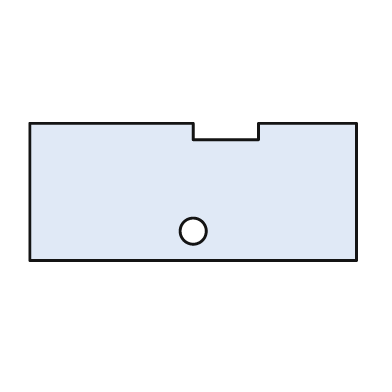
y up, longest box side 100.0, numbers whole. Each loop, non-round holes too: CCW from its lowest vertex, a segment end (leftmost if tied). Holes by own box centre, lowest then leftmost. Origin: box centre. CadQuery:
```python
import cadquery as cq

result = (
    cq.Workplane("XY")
    .moveTo(-50.0, -21.0)
    .lineTo(50.0, -21.0)
    .lineTo(50.0, 21.0)
    .lineTo(20.0, 21.0)
    .lineTo(20.0, 16.0)
    .lineTo(0.0, 16.0)
    .lineTo(0.0, 21.0)
    .lineTo(-50.0, 21.0)
    .close()
    .moveTo(0.0, -12.0)
    .circle(4.0)
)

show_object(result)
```